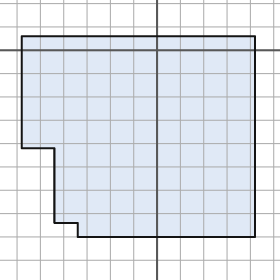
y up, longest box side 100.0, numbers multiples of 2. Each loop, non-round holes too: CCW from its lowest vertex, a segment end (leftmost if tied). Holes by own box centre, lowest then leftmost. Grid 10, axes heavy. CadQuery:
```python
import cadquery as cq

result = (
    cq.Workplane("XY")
    .moveTo(-34.0, -80.0)
    .lineTo(42.0, -80.0)
    .lineTo(42.0, 6.0)
    .lineTo(-58.0, 6.0)
    .lineTo(-58.0, -42.0)
    .lineTo(-44.0, -42.0)
    .lineTo(-44.0, -74.0)
    .lineTo(-34.0, -74.0)
    .close()
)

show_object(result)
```